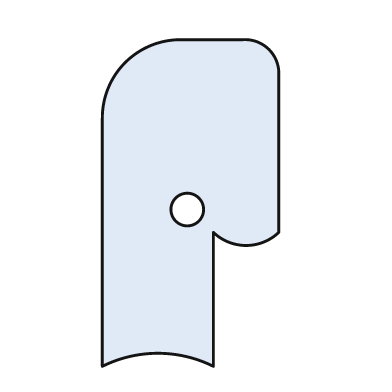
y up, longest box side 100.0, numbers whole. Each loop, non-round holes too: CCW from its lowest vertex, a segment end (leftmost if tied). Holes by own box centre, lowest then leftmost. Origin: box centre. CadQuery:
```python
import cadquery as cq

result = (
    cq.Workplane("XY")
    .moveTo(-27.0, -50.0)
    .threePointArc((-10.0, -46.0), (7.0, -50.0))
    .lineTo(7.0, -9.0)
    .threePointArc((17.0, -13.0), (27.0, -9.0))
    .lineTo(27.0, 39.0)
    .threePointArc((24.0, 47.0), (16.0, 50.0))
    .lineTo(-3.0, 50.0)
    .threePointArc((-20.0, 43.0), (-27.0, 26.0))
    .close()
    .moveTo(-1.0, -2.0)
    .circle(5.0)
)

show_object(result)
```